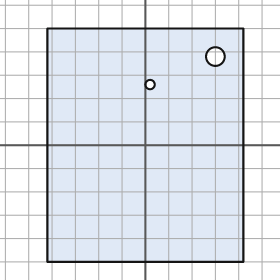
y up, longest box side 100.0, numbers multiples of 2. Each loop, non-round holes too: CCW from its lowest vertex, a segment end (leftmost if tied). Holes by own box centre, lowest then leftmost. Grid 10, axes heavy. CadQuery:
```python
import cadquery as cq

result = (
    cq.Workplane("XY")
    .moveTo(-42.0, -50.0)
    .lineTo(42.0, -50.0)
    .lineTo(42.0, 50.0)
    .lineTo(-42.0, 50.0)
    .close()
    .moveTo(2.0, 26.0)
    .circle(2.0)
    .moveTo(30.0, 38.0)
    .circle(4.0)
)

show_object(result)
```